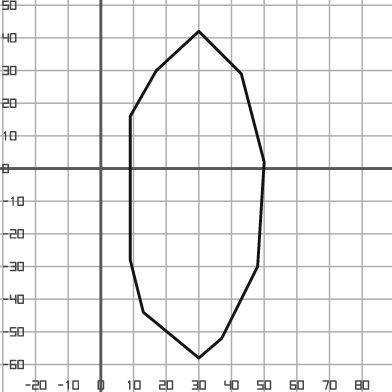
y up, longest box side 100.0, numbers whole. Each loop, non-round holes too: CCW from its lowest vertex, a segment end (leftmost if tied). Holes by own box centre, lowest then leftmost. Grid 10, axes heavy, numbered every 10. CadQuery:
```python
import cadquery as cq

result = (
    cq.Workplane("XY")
    .moveTo(30.0, -58.0)
    .lineTo(37.0, -52.0)
    .lineTo(48.0, -30.0)
    .lineTo(50.0, 2.0)
    .lineTo(43.0, 29.0)
    .lineTo(30.0, 42.0)
    .lineTo(17.0, 30.0)
    .lineTo(9.0, 16.0)
    .lineTo(9.0, -28.0)
    .lineTo(13.0, -44.0)
    .close()
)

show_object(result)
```